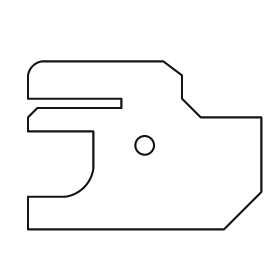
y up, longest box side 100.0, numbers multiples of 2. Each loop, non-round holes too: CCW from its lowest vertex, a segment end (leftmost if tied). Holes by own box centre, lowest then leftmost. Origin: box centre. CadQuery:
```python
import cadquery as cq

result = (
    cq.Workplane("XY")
    .moveTo(-50.0, -36.0)
    .lineTo(34.0, -36.0)
    .lineTo(50.0, -20.0)
    .lineTo(50.0, 12.0)
    .lineTo(24.0, 12.0)
    .lineTo(16.0, 20.0)
    .lineTo(16.0, 30.0)
    .lineTo(8.0, 36.0)
    .lineTo(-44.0, 36.0)
    .threePointArc((-48.0, 34.0), (-50.0, 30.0))
    .lineTo(-50.0, 20.0)
    .lineTo(-10.0, 20.0)
    .lineTo(-10.0, 16.0)
    .lineTo(-46.0, 16.0)
    .lineTo(-50.0, 12.0)
    .lineTo(-50.0, 6.0)
    .lineTo(-22.0, 6.0)
    .lineTo(-22.0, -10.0)
    .threePointArc((-26.0, -18.0), (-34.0, -22.0))
    .lineTo(-50.0, -22.0)
    .close()
    .moveTo(0.0, 0.0)
    .circle(4.0)
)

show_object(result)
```